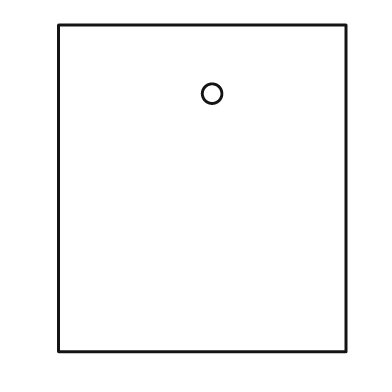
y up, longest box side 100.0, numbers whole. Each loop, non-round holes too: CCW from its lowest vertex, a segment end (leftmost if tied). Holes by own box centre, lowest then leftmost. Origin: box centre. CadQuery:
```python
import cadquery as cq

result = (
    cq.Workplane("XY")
    .moveTo(-44.0, -50.0)
    .lineTo(44.0, -50.0)
    .lineTo(44.0, 50.0)
    .lineTo(-44.0, 50.0)
    .close()
    .moveTo(3.0, 29.0)
    .circle(3.0)
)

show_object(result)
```